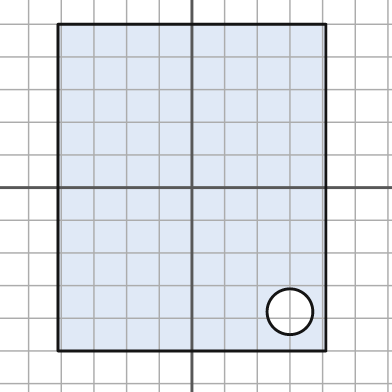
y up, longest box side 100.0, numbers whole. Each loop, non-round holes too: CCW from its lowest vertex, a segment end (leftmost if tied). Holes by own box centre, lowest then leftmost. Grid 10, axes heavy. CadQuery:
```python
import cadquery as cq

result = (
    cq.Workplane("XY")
    .moveTo(-41.0, -50.0)
    .lineTo(41.0, -50.0)
    .lineTo(41.0, 50.0)
    .lineTo(-41.0, 50.0)
    .close()
    .moveTo(30.0, -38.0)
    .circle(7.0)
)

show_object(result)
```